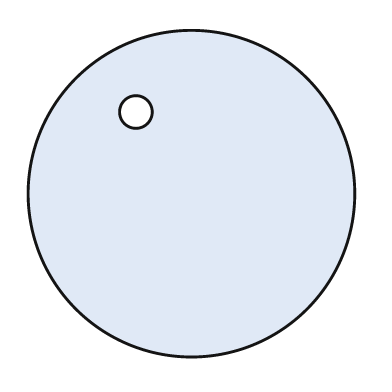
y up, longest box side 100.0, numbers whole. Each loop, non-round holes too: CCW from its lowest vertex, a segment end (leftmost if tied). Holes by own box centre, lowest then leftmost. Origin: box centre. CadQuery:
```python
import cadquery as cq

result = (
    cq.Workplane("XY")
    .moveTo(0.0, 0.0)
    .circle(50.0)
    .moveTo(-17.0, 25.0)
    .circle(5.0)
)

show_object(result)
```